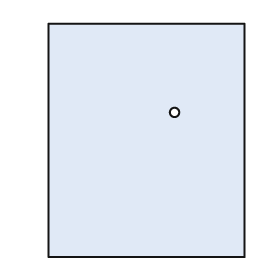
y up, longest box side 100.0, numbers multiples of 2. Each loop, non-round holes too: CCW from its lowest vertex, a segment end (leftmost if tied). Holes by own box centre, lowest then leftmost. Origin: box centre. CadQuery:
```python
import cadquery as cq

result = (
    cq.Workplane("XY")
    .moveTo(-42.0, -50.0)
    .lineTo(42.0, -50.0)
    .lineTo(42.0, 50.0)
    .lineTo(-42.0, 50.0)
    .close()
    .moveTo(12.0, 12.0)
    .circle(2.0)
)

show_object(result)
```